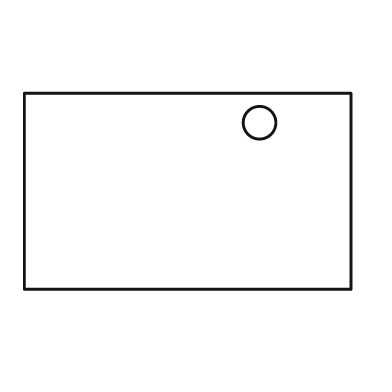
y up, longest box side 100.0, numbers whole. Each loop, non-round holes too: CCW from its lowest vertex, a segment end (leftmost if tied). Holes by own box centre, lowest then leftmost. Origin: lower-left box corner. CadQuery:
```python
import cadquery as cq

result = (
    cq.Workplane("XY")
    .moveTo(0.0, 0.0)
    .lineTo(100.0, 0.0)
    .lineTo(100.0, 60.0)
    .lineTo(0.0, 60.0)
    .close()
    .moveTo(72.0, 51.0)
    .circle(5.0)
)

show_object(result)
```